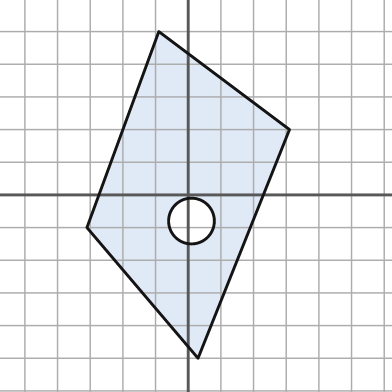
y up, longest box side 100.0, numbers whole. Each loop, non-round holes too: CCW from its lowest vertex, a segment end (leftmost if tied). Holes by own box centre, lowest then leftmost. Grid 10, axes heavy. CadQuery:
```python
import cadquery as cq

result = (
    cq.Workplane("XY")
    .moveTo(3.0, -50.0)
    .lineTo(31.0, 20.0)
    .lineTo(-9.0, 50.0)
    .lineTo(-31.0, -10.0)
    .close()
    .moveTo(1.0, -8.0)
    .circle(7.0)
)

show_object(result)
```